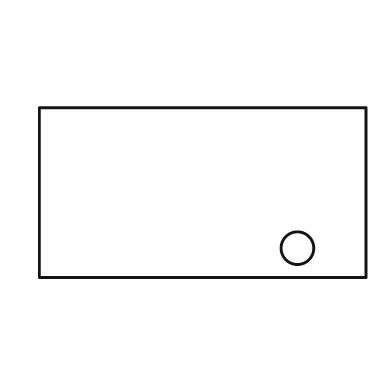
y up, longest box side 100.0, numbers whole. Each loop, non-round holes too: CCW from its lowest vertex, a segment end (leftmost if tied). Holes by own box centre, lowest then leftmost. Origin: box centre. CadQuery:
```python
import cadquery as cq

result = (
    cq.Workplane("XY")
    .moveTo(-50.0, -26.0)
    .lineTo(50.0, -26.0)
    .lineTo(50.0, 26.0)
    .lineTo(-50.0, 26.0)
    .close()
    .moveTo(29.0, -17.0)
    .circle(5.0)
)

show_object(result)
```